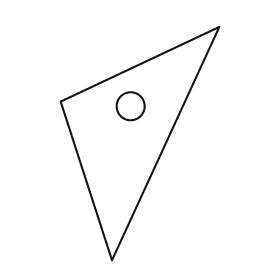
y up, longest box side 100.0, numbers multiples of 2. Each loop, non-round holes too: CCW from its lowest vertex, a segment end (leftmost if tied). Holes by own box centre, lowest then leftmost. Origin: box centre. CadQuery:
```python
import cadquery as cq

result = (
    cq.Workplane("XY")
    .moveTo(-12.0, -50.0)
    .lineTo(34.0, 50.0)
    .lineTo(-34.0, 18.0)
    .close()
    .moveTo(-4.0, 16.0)
    .circle(6.0)
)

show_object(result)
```